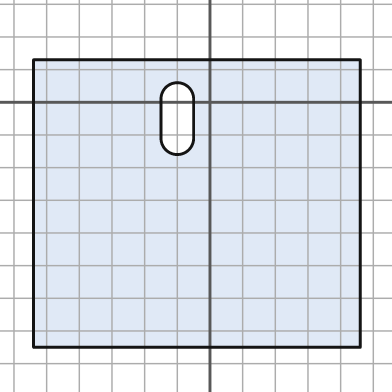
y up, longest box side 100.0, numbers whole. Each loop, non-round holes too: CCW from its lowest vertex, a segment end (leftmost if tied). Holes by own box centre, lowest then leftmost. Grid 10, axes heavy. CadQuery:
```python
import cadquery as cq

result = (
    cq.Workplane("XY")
    .moveTo(-54.0, -75.0)
    .lineTo(46.0, -75.0)
    .lineTo(46.0, 13.0)
    .lineTo(-54.0, 13.0)
    .close()
    .moveTo(-15.0, -11.0)
    .threePointArc((-10.0, -16.0), (-5.0, -11.0))
    .lineTo(-5.0, 1.0)
    .threePointArc((-10.0, 6.0), (-15.0, 1.0))
    .close()
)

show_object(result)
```